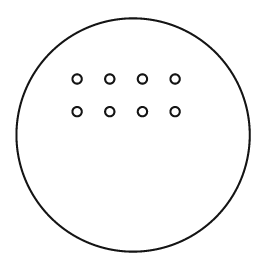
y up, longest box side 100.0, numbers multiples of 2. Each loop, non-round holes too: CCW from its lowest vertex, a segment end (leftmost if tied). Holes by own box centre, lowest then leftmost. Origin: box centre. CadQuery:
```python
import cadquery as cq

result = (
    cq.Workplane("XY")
    .moveTo(0.0, 0.0)
    .circle(50.0)
    .moveTo(-24.0, 10.0)
    .circle(2.0)
    .moveTo(-10.0, 10.0)
    .circle(2.0)
    .moveTo(4.0, 10.0)
    .circle(2.0)
    .moveTo(18.0, 10.0)
    .circle(2.0)
    .moveTo(-24.0, 24.0)
    .circle(2.0)
    .moveTo(-10.0, 24.0)
    .circle(2.0)
    .moveTo(4.0, 24.0)
    .circle(2.0)
    .moveTo(18.0, 24.0)
    .circle(2.0)
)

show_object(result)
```